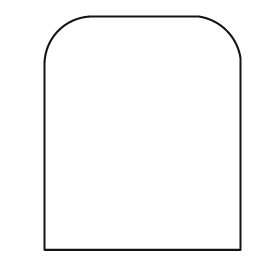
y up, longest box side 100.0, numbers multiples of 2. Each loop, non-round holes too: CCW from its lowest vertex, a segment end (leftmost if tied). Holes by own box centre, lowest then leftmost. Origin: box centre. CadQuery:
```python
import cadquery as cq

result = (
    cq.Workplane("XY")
    .moveTo(-42.0, -50.0)
    .lineTo(42.0, -50.0)
    .lineTo(42.0, 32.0)
    .threePointArc((36.0, 44.0), (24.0, 50.0))
    .lineTo(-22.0, 50.0)
    .threePointArc((-36.0, 44.0), (-42.0, 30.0))
    .close()
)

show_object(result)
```